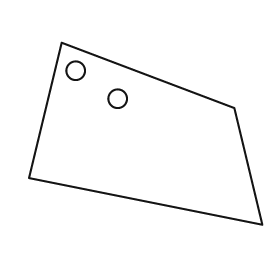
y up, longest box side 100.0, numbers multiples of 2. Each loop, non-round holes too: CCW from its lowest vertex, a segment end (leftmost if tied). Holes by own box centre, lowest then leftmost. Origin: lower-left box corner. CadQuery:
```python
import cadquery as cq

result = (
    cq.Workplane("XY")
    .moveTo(100.0, 0.0)
    .lineTo(88.0, 50.0)
    .lineTo(14.0, 78.0)
    .lineTo(0.0, 20.0)
    .close()
    .moveTo(38.0, 54.0)
    .circle(4.0)
    .moveTo(20.0, 66.0)
    .circle(4.0)
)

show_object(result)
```